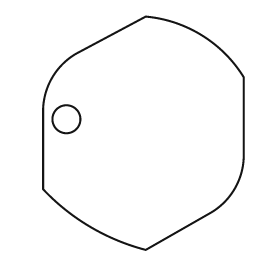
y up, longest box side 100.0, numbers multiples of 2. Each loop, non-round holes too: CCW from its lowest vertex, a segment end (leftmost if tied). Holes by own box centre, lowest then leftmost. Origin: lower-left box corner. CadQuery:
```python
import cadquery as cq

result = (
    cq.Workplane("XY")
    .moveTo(44.0, 0.0)
    .lineTo(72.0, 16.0)
    .threePointArc((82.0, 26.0), (86.0, 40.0))
    .lineTo(86.0, 74.0)
    .threePointArc((68.0, 92.0), (44.0, 100.0))
    .lineTo(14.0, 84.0)
    .threePointArc((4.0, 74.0), (0.0, 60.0))
    .lineTo(0.0, 26.0)
    .threePointArc((20.0, 10.0), (44.0, 0.0))
    .close()
    .moveTo(10.0, 56.0)
    .circle(6.0)
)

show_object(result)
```